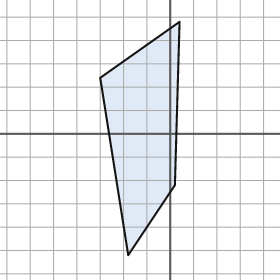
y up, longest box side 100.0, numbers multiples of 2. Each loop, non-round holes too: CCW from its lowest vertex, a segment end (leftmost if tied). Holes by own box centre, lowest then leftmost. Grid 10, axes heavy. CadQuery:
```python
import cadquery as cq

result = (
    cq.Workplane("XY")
    .moveTo(-18.0, -52.0)
    .lineTo(2.0, -22.0)
    .lineTo(4.0, 48.0)
    .lineTo(-30.0, 24.0)
    .close()
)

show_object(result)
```